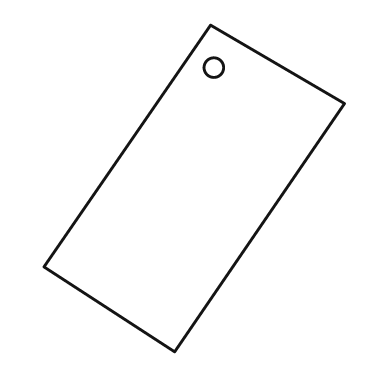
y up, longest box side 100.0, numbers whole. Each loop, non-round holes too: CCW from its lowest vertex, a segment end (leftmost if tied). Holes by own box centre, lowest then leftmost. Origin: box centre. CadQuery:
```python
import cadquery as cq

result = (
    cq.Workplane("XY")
    .moveTo(-6.0, -50.0)
    .lineTo(46.0, 26.0)
    .lineTo(5.0, 50.0)
    .lineTo(-46.0, -24.0)
    .close()
    .moveTo(6.0, 37.0)
    .circle(3.0)
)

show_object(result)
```